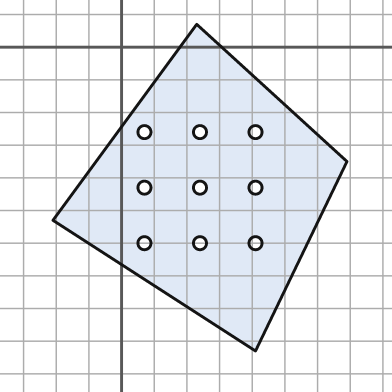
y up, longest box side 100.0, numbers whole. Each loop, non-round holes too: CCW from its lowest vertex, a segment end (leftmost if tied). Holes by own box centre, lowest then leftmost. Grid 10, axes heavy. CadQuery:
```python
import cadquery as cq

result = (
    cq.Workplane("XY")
    .moveTo(41.0, -93.0)
    .lineTo(69.0, -35.0)
    .lineTo(23.0, 7.0)
    .lineTo(-21.0, -53.0)
    .close()
    .moveTo(7.0, -60.0)
    .circle(2.0)
    .moveTo(24.0, -60.0)
    .circle(2.0)
    .moveTo(41.0, -60.0)
    .circle(2.0)
    .moveTo(7.0, -43.0)
    .circle(2.0)
    .moveTo(24.0, -43.0)
    .circle(2.0)
    .moveTo(41.0, -43.0)
    .circle(2.0)
    .moveTo(7.0, -26.0)
    .circle(2.0)
    .moveTo(24.0, -26.0)
    .circle(2.0)
    .moveTo(41.0, -26.0)
    .circle(2.0)
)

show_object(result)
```